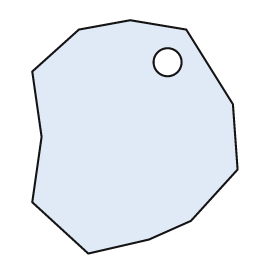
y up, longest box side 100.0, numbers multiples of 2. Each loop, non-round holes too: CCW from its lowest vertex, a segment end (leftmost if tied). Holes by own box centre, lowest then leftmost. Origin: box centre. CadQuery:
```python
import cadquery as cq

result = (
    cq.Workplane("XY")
    .moveTo(-20.0, -50.0)
    .lineTo(6.0, -44.0)
    .lineTo(24.0, -36.0)
    .lineTo(44.0, -14.0)
    .lineTo(42.0, 14.0)
    .lineTo(22.0, 46.0)
    .lineTo(-2.0, 50.0)
    .lineTo(-24.0, 46.0)
    .lineTo(-44.0, 28.0)
    .lineTo(-40.0, 0.0)
    .lineTo(-44.0, -28.0)
    .close()
    .moveTo(14.0, 32.0)
    .circle(6.0)
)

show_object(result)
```